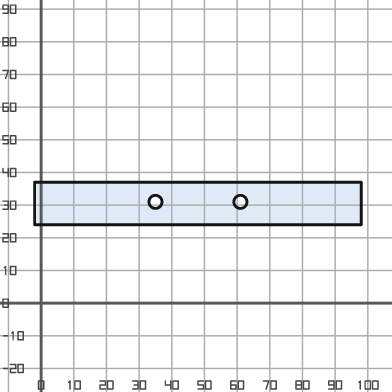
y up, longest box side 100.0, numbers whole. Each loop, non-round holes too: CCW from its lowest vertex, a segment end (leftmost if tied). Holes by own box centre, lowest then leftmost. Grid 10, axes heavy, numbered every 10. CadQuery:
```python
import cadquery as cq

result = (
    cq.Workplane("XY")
    .moveTo(-2.0, 24.0)
    .lineTo(98.0, 24.0)
    .lineTo(98.0, 37.0)
    .lineTo(-2.0, 37.0)
    .close()
    .moveTo(35.0, 31.0)
    .circle(2.0)
    .moveTo(61.0, 31.0)
    .circle(2.0)
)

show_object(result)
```